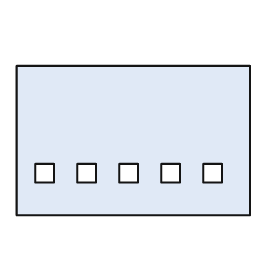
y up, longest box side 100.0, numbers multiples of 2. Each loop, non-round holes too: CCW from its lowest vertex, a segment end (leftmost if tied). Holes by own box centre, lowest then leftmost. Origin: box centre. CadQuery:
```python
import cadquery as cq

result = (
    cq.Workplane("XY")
    .moveTo(-50.0, -32.0)
    .lineTo(50.0, -32.0)
    .lineTo(50.0, 32.0)
    .lineTo(-50.0, 32.0)
    .close()
    .moveTo(-42.0, -18.0)
    .lineTo(-34.0, -18.0)
    .lineTo(-34.0, -10.0)
    .lineTo(-42.0, -10.0)
    .close()
    .moveTo(-24.0, -18.0)
    .lineTo(-16.0, -18.0)
    .lineTo(-16.0, -10.0)
    .lineTo(-24.0, -10.0)
    .close()
    .moveTo(-6.0, -18.0)
    .lineTo(2.0, -18.0)
    .lineTo(2.0, -10.0)
    .lineTo(-6.0, -10.0)
    .close()
    .moveTo(12.0, -18.0)
    .lineTo(20.0, -18.0)
    .lineTo(20.0, -10.0)
    .lineTo(12.0, -10.0)
    .close()
    .moveTo(30.0, -18.0)
    .lineTo(38.0, -18.0)
    .lineTo(38.0, -10.0)
    .lineTo(30.0, -10.0)
    .close()
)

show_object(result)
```